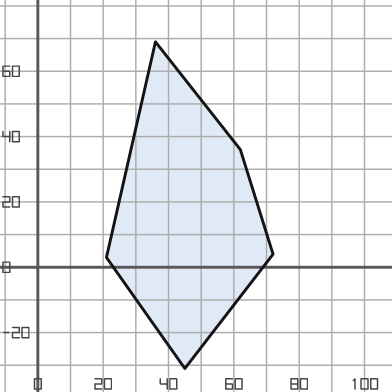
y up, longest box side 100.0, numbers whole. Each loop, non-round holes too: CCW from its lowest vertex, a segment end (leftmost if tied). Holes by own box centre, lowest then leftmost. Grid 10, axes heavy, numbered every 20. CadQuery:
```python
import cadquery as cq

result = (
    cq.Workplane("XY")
    .moveTo(45.0, -31.0)
    .lineTo(72.0, 4.0)
    .lineTo(62.0, 36.0)
    .lineTo(36.0, 69.0)
    .lineTo(21.0, 3.0)
    .close()
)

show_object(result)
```